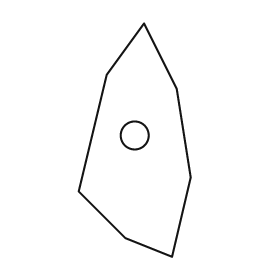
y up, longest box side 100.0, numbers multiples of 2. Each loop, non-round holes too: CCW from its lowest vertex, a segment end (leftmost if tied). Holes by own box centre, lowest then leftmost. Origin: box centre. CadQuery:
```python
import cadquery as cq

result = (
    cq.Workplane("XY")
    .moveTo(16.0, -50.0)
    .lineTo(24.0, -16.0)
    .lineTo(18.0, 22.0)
    .lineTo(4.0, 50.0)
    .lineTo(-12.0, 28.0)
    .lineTo(-24.0, -22.0)
    .lineTo(-4.0, -42.0)
    .close()
    .moveTo(0.0, 2.0)
    .circle(6.0)
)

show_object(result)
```